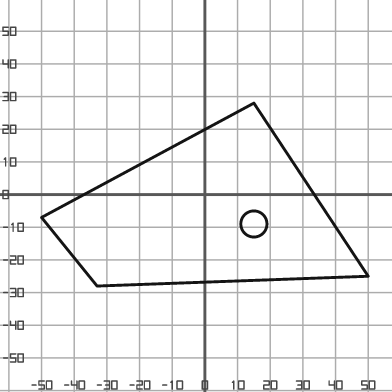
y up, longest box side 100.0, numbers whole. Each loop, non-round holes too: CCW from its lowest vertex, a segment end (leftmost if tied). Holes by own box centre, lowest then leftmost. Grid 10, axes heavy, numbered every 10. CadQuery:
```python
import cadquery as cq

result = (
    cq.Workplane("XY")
    .moveTo(-33.0, -28.0)
    .lineTo(50.0, -25.0)
    .lineTo(15.0, 28.0)
    .lineTo(-50.0, -7.0)
    .close()
    .moveTo(15.0, -9.0)
    .circle(4.0)
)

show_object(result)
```